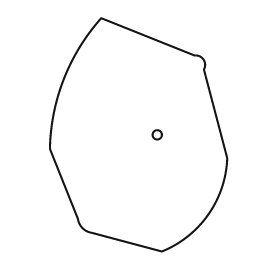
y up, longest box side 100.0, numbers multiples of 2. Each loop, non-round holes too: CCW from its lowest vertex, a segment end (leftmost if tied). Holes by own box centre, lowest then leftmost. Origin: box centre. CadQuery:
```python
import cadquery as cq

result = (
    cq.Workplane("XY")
    .moveTo(10.0, -50.0)
    .threePointArc((30.0, -34.0), (38.0, -10.0))
    .lineTo(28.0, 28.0)
    .threePointArc((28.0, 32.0), (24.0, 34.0))
    .lineTo(-16.0, 50.0)
    .threePointArc((-32.0, 24.0), (-38.0, -6.0))
    .lineTo(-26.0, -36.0)
    .threePointArc((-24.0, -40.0), (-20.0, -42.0))
    .close()
    .moveTo(8.0, 0.0)
    .circle(2.0)
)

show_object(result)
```